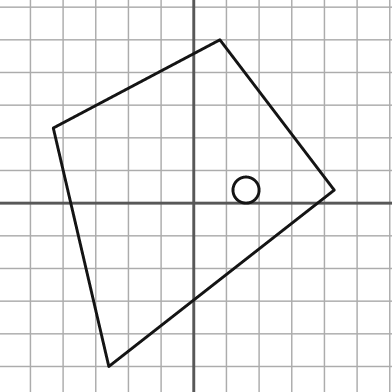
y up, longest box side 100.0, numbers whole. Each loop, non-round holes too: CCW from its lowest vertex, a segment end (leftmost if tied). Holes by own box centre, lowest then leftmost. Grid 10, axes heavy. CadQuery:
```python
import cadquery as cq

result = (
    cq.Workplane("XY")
    .moveTo(-26.0, -50.0)
    .lineTo(43.0, 4.0)
    .lineTo(8.0, 50.0)
    .lineTo(-43.0, 23.0)
    .close()
    .moveTo(16.0, 4.0)
    .circle(4.0)
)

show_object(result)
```